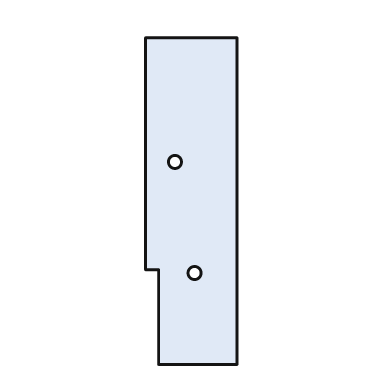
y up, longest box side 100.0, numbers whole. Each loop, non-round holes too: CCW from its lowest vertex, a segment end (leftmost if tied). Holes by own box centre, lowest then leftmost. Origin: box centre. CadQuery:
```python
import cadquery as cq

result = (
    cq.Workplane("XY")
    .moveTo(-10.0, -50.0)
    .lineTo(14.0, -50.0)
    .lineTo(14.0, 50.0)
    .lineTo(-14.0, 50.0)
    .lineTo(-14.0, -21.0)
    .lineTo(-10.0, -21.0)
    .close()
    .moveTo(1.0, -22.0)
    .circle(2.0)
    .moveTo(-5.0, 12.0)
    .circle(2.0)
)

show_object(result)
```